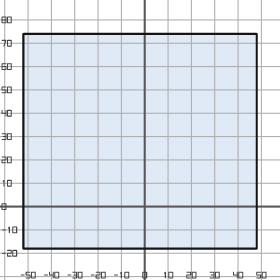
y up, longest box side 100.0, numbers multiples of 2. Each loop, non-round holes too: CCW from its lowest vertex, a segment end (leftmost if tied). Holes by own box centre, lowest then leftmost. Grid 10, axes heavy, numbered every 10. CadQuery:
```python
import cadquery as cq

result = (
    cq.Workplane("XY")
    .moveTo(-52.0, -18.0)
    .lineTo(48.0, -18.0)
    .lineTo(48.0, 74.0)
    .lineTo(-52.0, 74.0)
    .close()
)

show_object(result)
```